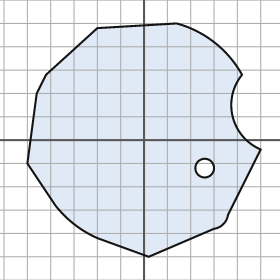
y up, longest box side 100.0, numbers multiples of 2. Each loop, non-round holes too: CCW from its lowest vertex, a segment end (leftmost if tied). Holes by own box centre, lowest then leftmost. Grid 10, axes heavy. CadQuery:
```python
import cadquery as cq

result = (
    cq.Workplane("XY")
    .moveTo(2.0, -50.0)
    .lineTo(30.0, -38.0)
    .threePointArc((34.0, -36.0), (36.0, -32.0))
    .lineTo(50.0, -4.0)
    .threePointArc((38.0, 10.0), (42.0, 28.0))
    .threePointArc((30.0, 42.0), (14.0, 50.0))
    .lineTo(-20.0, 48.0)
    .lineTo(-42.0, 28.0)
    .lineTo(-46.0, 20.0)
    .lineTo(-50.0, -10.0)
    .lineTo(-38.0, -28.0)
    .threePointArc((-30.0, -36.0), (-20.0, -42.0))
    .close()
    .moveTo(26.0, -12.0)
    .circle(4.0)
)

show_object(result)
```